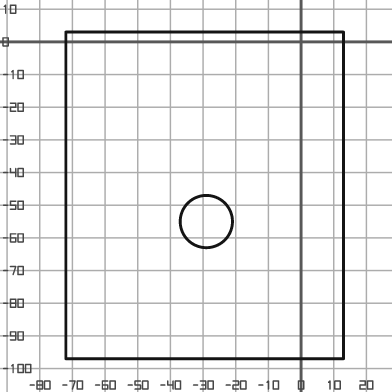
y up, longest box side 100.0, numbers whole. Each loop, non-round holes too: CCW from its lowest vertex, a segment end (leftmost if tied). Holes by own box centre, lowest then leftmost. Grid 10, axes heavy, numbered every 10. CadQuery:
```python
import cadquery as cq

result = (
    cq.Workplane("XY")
    .moveTo(-72.0, -97.0)
    .lineTo(13.0, -97.0)
    .lineTo(13.0, 3.0)
    .lineTo(-72.0, 3.0)
    .close()
    .moveTo(-29.0, -55.0)
    .circle(8.0)
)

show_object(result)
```